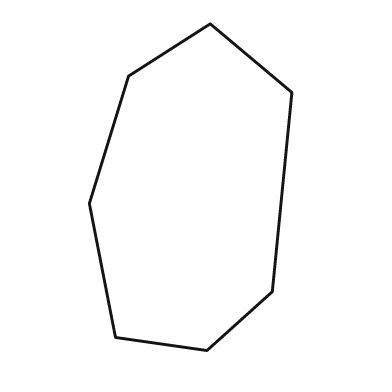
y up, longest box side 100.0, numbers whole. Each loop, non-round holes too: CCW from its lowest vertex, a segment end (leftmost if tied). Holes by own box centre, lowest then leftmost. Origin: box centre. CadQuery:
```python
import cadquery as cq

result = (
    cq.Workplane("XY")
    .moveTo(5.0, -50.0)
    .lineTo(25.0, -32.0)
    .lineTo(31.0, 29.0)
    .lineTo(6.0, 50.0)
    .lineTo(-19.0, 34.0)
    .lineTo(-31.0, -5.0)
    .lineTo(-23.0, -46.0)
    .close()
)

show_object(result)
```